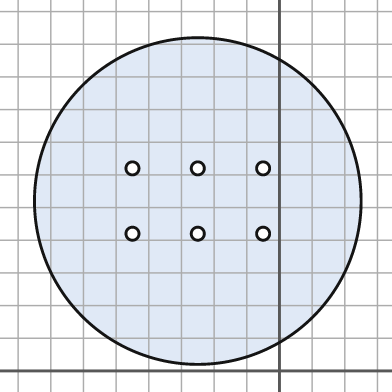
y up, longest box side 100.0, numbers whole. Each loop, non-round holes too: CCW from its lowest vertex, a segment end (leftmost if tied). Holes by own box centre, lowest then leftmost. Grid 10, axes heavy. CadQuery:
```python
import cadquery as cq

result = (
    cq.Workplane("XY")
    .moveTo(-25.0, 52.0)
    .circle(50.0)
    .moveTo(-45.0, 42.0)
    .circle(2.0)
    .moveTo(-25.0, 42.0)
    .circle(2.0)
    .moveTo(-5.0, 42.0)
    .circle(2.0)
    .moveTo(-45.0, 62.0)
    .circle(2.0)
    .moveTo(-25.0, 62.0)
    .circle(2.0)
    .moveTo(-5.0, 62.0)
    .circle(2.0)
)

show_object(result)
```